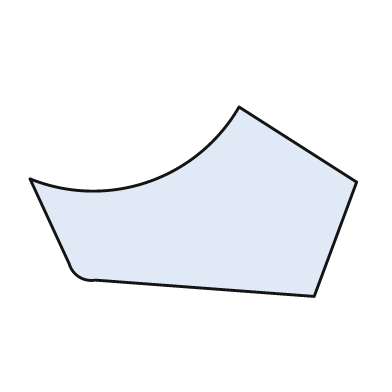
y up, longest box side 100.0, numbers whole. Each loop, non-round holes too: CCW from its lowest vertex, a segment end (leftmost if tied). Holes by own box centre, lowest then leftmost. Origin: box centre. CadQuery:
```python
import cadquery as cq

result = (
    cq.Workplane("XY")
    .moveTo(37.0, -29.0)
    .lineTo(50.0, 6.0)
    .lineTo(14.0, 29.0)
    .threePointArc((-14.0, 6.0), (-50.0, 7.0))
    .lineTo(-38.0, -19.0)
    .threePointArc((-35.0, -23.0), (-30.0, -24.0))
    .close()
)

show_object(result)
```